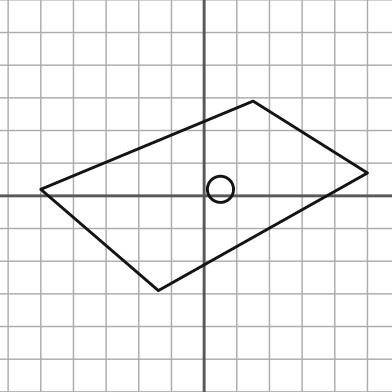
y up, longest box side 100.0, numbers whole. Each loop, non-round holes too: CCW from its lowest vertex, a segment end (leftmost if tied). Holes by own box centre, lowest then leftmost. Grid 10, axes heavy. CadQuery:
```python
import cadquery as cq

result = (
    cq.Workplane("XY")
    .moveTo(-14.0, -29.0)
    .lineTo(50.0, 7.0)
    .lineTo(15.0, 29.0)
    .lineTo(-50.0, 2.0)
    .close()
    .moveTo(5.0, 2.0)
    .circle(4.0)
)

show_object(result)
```